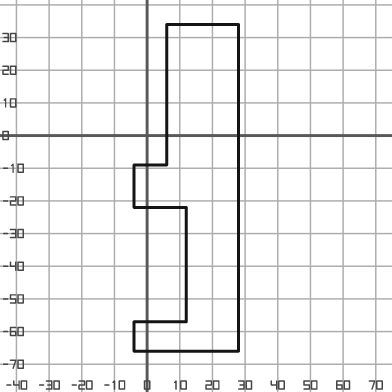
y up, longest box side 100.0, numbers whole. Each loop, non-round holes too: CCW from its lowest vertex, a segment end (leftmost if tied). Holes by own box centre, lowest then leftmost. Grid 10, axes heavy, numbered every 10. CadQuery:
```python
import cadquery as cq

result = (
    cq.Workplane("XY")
    .moveTo(-4.0, -66.0)
    .lineTo(28.0, -66.0)
    .lineTo(28.0, 34.0)
    .lineTo(6.0, 34.0)
    .lineTo(6.0, -9.0)
    .lineTo(-4.0, -9.0)
    .lineTo(-4.0, -22.0)
    .lineTo(12.0, -22.0)
    .lineTo(12.0, -57.0)
    .lineTo(-4.0, -57.0)
    .close()
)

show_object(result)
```